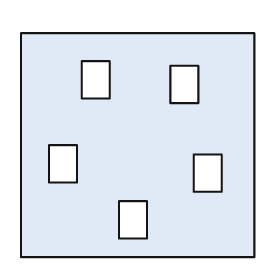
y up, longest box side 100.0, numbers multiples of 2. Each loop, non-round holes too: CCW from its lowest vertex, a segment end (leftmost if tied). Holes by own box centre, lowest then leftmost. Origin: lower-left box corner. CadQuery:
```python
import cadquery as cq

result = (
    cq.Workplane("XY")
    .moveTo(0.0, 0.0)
    .lineTo(100.0, 0.0)
    .lineTo(100.0, 96.0)
    .lineTo(0.0, 96.0)
    .close()
    .moveTo(42.0, 8.0)
    .lineTo(54.0, 8.0)
    .lineTo(54.0, 24.0)
    .lineTo(42.0, 24.0)
    .close()
    .moveTo(74.0, 28.0)
    .lineTo(86.0, 28.0)
    .lineTo(86.0, 44.0)
    .lineTo(74.0, 44.0)
    .close()
    .moveTo(12.0, 32.0)
    .lineTo(24.0, 32.0)
    .lineTo(24.0, 48.0)
    .lineTo(12.0, 48.0)
    .close()
    .moveTo(64.0, 66.0)
    .lineTo(76.0, 66.0)
    .lineTo(76.0, 82.0)
    .lineTo(64.0, 82.0)
    .close()
    .moveTo(26.0, 68.0)
    .lineTo(38.0, 68.0)
    .lineTo(38.0, 84.0)
    .lineTo(26.0, 84.0)
    .close()
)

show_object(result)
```